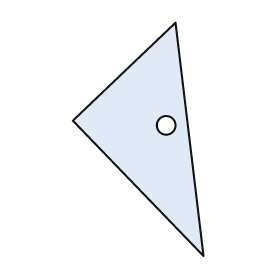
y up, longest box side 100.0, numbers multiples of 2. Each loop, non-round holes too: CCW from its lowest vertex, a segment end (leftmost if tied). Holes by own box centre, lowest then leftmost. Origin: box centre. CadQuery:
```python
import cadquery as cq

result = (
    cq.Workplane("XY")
    .moveTo(28.0, -50.0)
    .lineTo(16.0, 50.0)
    .lineTo(-28.0, 8.0)
    .close()
    .moveTo(12.0, 6.0)
    .circle(4.0)
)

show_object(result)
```